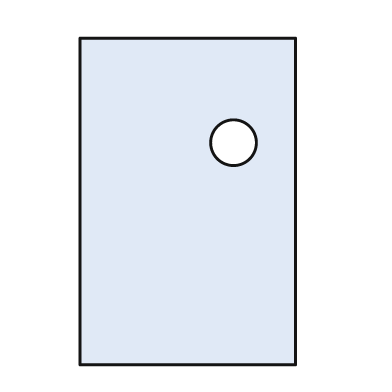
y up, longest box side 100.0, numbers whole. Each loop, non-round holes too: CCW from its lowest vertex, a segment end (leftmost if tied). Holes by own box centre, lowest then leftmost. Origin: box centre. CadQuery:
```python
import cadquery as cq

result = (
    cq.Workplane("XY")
    .moveTo(-33.0, -50.0)
    .lineTo(33.0, -50.0)
    .lineTo(33.0, 50.0)
    .lineTo(-33.0, 50.0)
    .close()
    .moveTo(14.0, 18.0)
    .circle(7.0)
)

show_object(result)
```